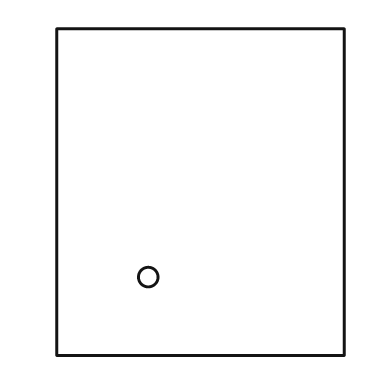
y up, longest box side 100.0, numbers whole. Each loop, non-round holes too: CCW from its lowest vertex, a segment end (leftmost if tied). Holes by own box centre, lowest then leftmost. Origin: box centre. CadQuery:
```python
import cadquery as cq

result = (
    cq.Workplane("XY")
    .moveTo(-44.0, -50.0)
    .lineTo(44.0, -50.0)
    .lineTo(44.0, 50.0)
    .lineTo(-44.0, 50.0)
    .close()
    .moveTo(-16.0, -26.0)
    .circle(3.0)
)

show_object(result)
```